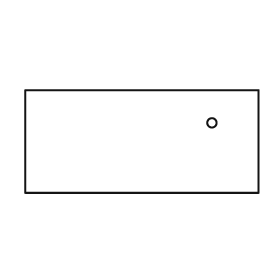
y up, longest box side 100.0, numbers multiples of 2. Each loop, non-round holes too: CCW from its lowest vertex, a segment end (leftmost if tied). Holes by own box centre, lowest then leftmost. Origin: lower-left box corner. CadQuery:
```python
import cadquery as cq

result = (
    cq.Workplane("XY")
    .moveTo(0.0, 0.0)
    .lineTo(100.0, 0.0)
    .lineTo(100.0, 44.0)
    .lineTo(0.0, 44.0)
    .close()
    .moveTo(80.0, 30.0)
    .circle(2.0)
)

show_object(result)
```